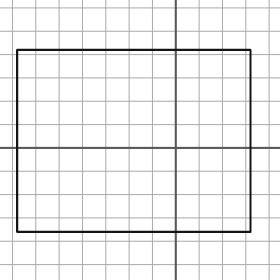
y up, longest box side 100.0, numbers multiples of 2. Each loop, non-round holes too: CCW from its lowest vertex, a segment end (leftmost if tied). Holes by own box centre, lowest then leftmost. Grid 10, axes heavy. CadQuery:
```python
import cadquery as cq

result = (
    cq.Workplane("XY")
    .moveTo(-68.0, -36.0)
    .lineTo(32.0, -36.0)
    .lineTo(32.0, 42.0)
    .lineTo(-68.0, 42.0)
    .close()
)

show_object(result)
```